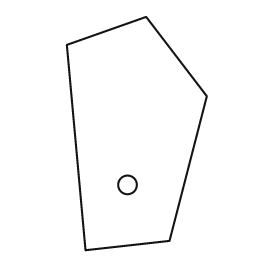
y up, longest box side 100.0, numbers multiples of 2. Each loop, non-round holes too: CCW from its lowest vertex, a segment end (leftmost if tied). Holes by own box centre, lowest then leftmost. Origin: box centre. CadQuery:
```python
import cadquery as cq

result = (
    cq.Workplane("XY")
    .moveTo(-22.0, -50.0)
    .lineTo(14.0, -46.0)
    .lineTo(30.0, 16.0)
    .lineTo(4.0, 50.0)
    .lineTo(-30.0, 38.0)
    .close()
    .moveTo(-4.0, -22.0)
    .circle(4.0)
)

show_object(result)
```